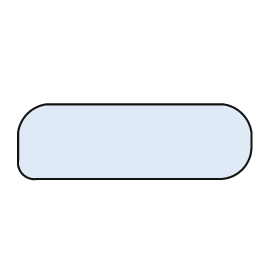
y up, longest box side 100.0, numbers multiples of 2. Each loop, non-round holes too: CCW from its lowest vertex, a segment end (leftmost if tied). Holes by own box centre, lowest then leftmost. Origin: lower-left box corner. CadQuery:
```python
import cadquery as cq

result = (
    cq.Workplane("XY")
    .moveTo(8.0, 0.0)
    .lineTo(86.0, 0.0)
    .threePointArc((96.0, 4.0), (100.0, 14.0))
    .lineTo(100.0, 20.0)
    .threePointArc((96.0, 28.0), (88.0, 32.0))
    .lineTo(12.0, 32.0)
    .threePointArc((4.0, 28.0), (0.0, 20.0))
    .lineTo(0.0, 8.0)
    .threePointArc((2.0, 2.0), (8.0, 0.0))
    .close()
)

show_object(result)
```